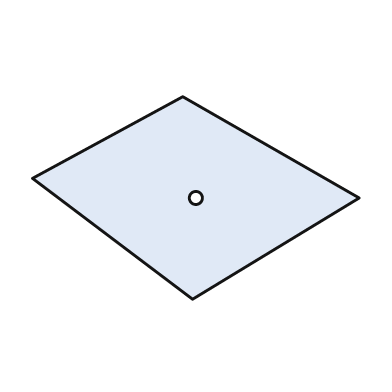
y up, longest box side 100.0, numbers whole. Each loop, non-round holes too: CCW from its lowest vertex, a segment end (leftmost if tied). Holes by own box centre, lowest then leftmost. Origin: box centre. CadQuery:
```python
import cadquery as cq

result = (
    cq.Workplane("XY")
    .moveTo(-1.0, -31.0)
    .lineTo(50.0, 0.0)
    .lineTo(-4.0, 31.0)
    .lineTo(-50.0, 6.0)
    .close()
    .moveTo(0.0, 0.0)
    .circle(2.0)
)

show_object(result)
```